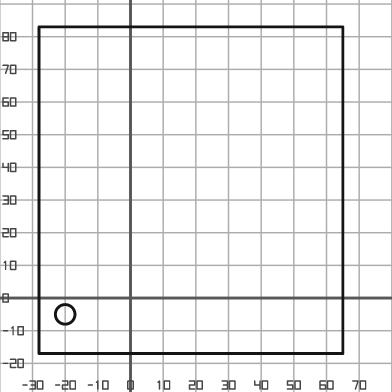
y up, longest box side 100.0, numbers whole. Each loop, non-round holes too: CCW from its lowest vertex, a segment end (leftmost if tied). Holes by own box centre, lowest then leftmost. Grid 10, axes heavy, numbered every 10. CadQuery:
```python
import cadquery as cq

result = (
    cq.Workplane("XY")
    .moveTo(-28.0, -17.0)
    .lineTo(65.0, -17.0)
    .lineTo(65.0, 83.0)
    .lineTo(-28.0, 83.0)
    .close()
    .moveTo(-20.0, -5.0)
    .circle(3.0)
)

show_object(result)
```